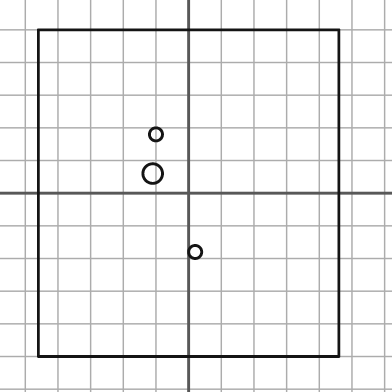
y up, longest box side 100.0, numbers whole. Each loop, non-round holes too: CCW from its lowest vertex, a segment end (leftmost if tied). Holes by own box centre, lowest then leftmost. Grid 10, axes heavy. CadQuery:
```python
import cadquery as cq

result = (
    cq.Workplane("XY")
    .moveTo(-46.0, -50.0)
    .lineTo(46.0, -50.0)
    .lineTo(46.0, 50.0)
    .lineTo(-46.0, 50.0)
    .close()
    .moveTo(2.0, -18.0)
    .circle(2.0)
    .moveTo(-11.0, 6.0)
    .circle(3.0)
    .moveTo(-10.0, 18.0)
    .circle(2.0)
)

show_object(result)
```